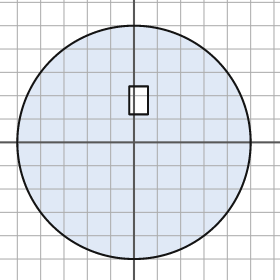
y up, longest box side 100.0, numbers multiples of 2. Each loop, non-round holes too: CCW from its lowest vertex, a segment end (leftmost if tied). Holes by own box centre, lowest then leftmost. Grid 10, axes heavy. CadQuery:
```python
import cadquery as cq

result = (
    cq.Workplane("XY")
    .moveTo(0.0, 0.0)
    .circle(50.0)
    .moveTo(-2.0, 12.0)
    .lineTo(6.0, 12.0)
    .lineTo(6.0, 24.0)
    .lineTo(-2.0, 24.0)
    .close()
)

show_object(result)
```